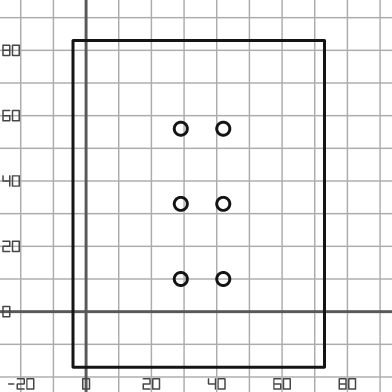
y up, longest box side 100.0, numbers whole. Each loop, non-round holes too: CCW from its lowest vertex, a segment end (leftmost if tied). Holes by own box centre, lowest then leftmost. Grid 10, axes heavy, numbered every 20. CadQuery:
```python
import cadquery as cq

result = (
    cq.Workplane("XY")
    .moveTo(-4.0, -17.0)
    .lineTo(73.0, -17.0)
    .lineTo(73.0, 83.0)
    .lineTo(-4.0, 83.0)
    .close()
    .moveTo(29.0, 10.0)
    .circle(2.0)
    .moveTo(42.0, 10.0)
    .circle(2.0)
    .moveTo(29.0, 33.0)
    .circle(2.0)
    .moveTo(42.0, 33.0)
    .circle(2.0)
    .moveTo(29.0, 56.0)
    .circle(2.0)
    .moveTo(42.0, 56.0)
    .circle(2.0)
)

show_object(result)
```